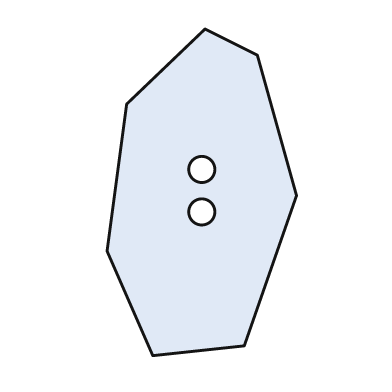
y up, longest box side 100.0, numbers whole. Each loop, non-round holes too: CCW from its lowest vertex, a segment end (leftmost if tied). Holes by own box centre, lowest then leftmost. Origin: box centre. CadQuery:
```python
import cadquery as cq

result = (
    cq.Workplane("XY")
    .moveTo(-15.0, -50.0)
    .lineTo(13.0, -47.0)
    .lineTo(29.0, -1.0)
    .lineTo(17.0, 42.0)
    .lineTo(1.0, 50.0)
    .lineTo(-23.0, 27.0)
    .lineTo(-29.0, -18.0)
    .close()
    .moveTo(0.0, -6.0)
    .circle(4.0)
    .moveTo(0.0, 7.0)
    .circle(4.0)
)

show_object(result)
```